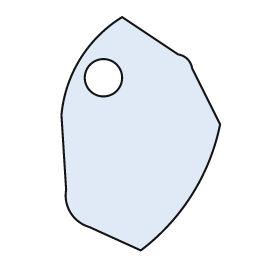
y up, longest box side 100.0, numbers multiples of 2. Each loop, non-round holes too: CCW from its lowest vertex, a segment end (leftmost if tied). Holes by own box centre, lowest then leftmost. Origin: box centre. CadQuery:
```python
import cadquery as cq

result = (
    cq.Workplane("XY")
    .moveTo(0.0, -50.0)
    .threePointArc((22.0, -26.0), (34.0, 4.0))
    .lineTo(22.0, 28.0)
    .threePointArc((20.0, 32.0), (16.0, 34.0))
    .lineTo(-8.0, 50.0)
    .threePointArc((-26.0, 32.0), (-34.0, 8.0))
    .lineTo(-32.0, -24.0)
    .threePointArc((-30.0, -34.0), (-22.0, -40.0))
    .close()
    .moveTo(-16.0, 24.0)
    .circle(8.0)
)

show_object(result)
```